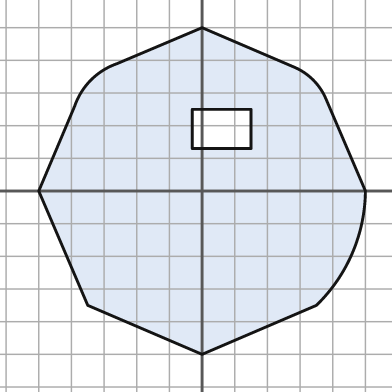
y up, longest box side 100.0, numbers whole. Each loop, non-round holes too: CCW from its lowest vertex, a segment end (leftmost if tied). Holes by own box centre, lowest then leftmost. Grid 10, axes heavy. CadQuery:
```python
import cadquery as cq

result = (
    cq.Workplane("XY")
    .moveTo(0.0, -50.0)
    .lineTo(35.0, -35.0)
    .threePointArc((46.0, -19.0), (50.0, 0.0))
    .lineTo(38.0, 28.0)
    .threePointArc((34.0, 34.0), (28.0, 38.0))
    .lineTo(0.0, 50.0)
    .lineTo(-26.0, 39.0)
    .threePointArc((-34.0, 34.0), (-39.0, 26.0))
    .lineTo(-50.0, 0.0)
    .lineTo(-35.0, -35.0)
    .close()
    .moveTo(-3.0, 13.0)
    .lineTo(15.0, 13.0)
    .lineTo(15.0, 25.0)
    .lineTo(-3.0, 25.0)
    .close()
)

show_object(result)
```